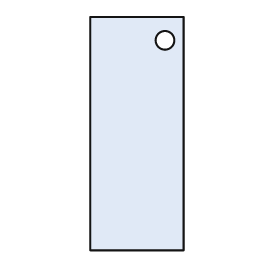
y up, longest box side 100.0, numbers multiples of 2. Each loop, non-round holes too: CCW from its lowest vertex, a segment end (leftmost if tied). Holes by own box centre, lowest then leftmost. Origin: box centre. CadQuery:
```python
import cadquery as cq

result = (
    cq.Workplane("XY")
    .moveTo(-20.0, -50.0)
    .lineTo(20.0, -50.0)
    .lineTo(20.0, 50.0)
    .lineTo(-20.0, 50.0)
    .close()
    .moveTo(12.0, 40.0)
    .circle(4.0)
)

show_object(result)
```